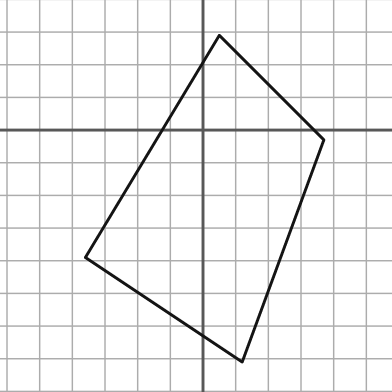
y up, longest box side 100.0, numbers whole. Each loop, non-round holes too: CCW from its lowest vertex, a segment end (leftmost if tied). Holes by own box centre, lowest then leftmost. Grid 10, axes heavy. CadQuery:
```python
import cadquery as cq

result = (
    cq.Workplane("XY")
    .moveTo(12.0, -71.0)
    .lineTo(37.0, -3.0)
    .lineTo(5.0, 29.0)
    .lineTo(-36.0, -39.0)
    .close()
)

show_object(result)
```